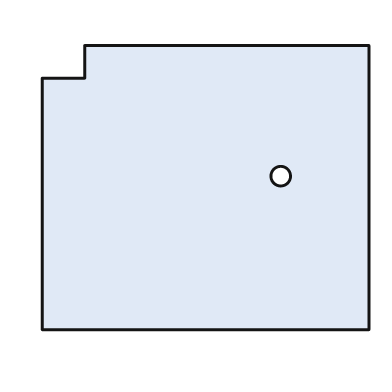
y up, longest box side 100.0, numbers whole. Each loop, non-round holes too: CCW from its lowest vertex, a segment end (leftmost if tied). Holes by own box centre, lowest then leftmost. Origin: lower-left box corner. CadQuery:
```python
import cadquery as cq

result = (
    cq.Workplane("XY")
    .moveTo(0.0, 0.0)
    .lineTo(100.0, 0.0)
    .lineTo(100.0, 87.0)
    .lineTo(13.0, 87.0)
    .lineTo(13.0, 77.0)
    .lineTo(0.0, 77.0)
    .close()
    .moveTo(73.0, 47.0)
    .circle(3.0)
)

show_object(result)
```